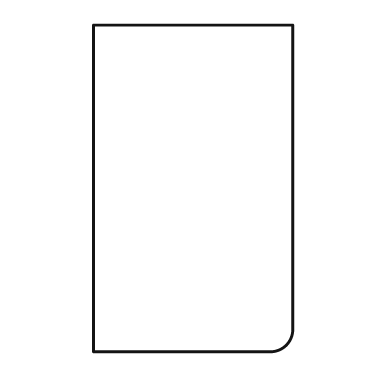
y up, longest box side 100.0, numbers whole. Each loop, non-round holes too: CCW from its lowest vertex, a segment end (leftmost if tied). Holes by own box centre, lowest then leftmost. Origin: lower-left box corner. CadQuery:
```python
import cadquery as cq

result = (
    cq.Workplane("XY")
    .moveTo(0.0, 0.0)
    .lineTo(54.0, 0.0)
    .threePointArc((59.0, 2.0), (61.0, 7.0))
    .lineTo(61.0, 100.0)
    .lineTo(0.0, 100.0)
    .close()
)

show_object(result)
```